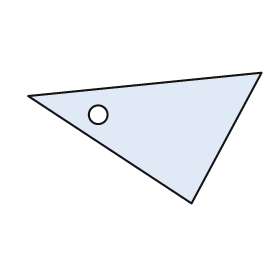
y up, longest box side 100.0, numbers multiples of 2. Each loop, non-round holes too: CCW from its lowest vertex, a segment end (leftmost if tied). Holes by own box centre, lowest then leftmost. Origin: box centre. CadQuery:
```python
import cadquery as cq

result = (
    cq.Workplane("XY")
    .moveTo(20.0, -28.0)
    .lineTo(50.0, 28.0)
    .lineTo(-50.0, 18.0)
    .close()
    .moveTo(-20.0, 10.0)
    .circle(4.0)
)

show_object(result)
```